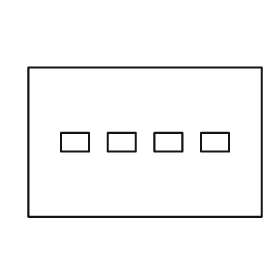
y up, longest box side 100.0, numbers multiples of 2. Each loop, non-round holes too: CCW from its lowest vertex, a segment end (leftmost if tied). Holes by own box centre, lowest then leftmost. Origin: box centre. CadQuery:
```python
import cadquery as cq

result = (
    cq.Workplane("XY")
    .moveTo(-50.0, -32.0)
    .lineTo(50.0, -32.0)
    .lineTo(50.0, 32.0)
    .lineTo(-50.0, 32.0)
    .close()
    .moveTo(-36.0, -4.0)
    .lineTo(-24.0, -4.0)
    .lineTo(-24.0, 4.0)
    .lineTo(-36.0, 4.0)
    .close()
    .moveTo(-16.0, -4.0)
    .lineTo(-4.0, -4.0)
    .lineTo(-4.0, 4.0)
    .lineTo(-16.0, 4.0)
    .close()
    .moveTo(4.0, -4.0)
    .lineTo(16.0, -4.0)
    .lineTo(16.0, 4.0)
    .lineTo(4.0, 4.0)
    .close()
    .moveTo(24.0, -4.0)
    .lineTo(36.0, -4.0)
    .lineTo(36.0, 4.0)
    .lineTo(24.0, 4.0)
    .close()
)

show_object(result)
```